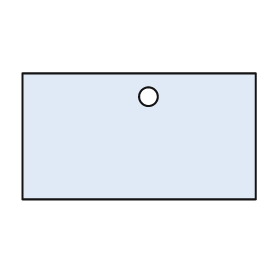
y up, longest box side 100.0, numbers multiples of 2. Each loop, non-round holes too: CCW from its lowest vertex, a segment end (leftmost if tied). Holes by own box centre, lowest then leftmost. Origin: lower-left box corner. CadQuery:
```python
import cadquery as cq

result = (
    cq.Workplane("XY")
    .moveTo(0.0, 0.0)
    .lineTo(100.0, 0.0)
    .lineTo(100.0, 54.0)
    .lineTo(0.0, 54.0)
    .close()
    .moveTo(54.0, 44.0)
    .circle(4.0)
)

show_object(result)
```